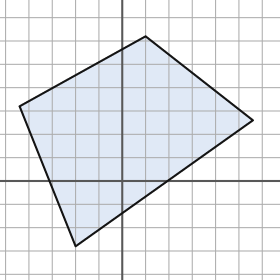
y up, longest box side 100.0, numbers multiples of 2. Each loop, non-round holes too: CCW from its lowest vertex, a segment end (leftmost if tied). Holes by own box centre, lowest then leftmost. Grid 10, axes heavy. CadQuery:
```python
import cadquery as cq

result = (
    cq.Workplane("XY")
    .moveTo(-20.0, -28.0)
    .lineTo(56.0, 26.0)
    .lineTo(10.0, 62.0)
    .lineTo(-44.0, 32.0)
    .close()
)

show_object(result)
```